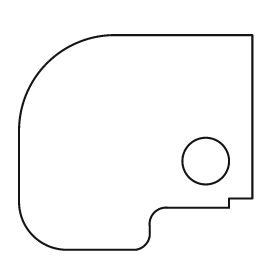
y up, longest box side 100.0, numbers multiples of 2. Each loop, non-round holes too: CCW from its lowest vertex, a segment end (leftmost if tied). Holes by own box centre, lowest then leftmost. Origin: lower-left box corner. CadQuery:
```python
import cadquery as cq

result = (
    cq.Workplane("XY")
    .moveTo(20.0, 0.0)
    .lineTo(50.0, 0.0)
    .threePointArc((54.0, 2.0), (56.0, 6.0))
    .lineTo(56.0, 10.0)
    .threePointArc((58.0, 16.0), (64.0, 18.0))
    .lineTo(90.0, 18.0)
    .lineTo(90.0, 22.0)
    .lineTo(100.0, 22.0)
    .lineTo(100.0, 92.0)
    .lineTo(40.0, 92.0)
    .threePointArc((12.0, 80.0), (0.0, 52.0))
    .lineTo(0.0, 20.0)
    .threePointArc((6.0, 6.0), (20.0, 0.0))
    .close()
    .moveTo(80.0, 38.0)
    .circle(10.0)
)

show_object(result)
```